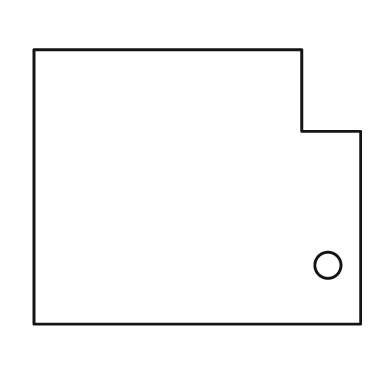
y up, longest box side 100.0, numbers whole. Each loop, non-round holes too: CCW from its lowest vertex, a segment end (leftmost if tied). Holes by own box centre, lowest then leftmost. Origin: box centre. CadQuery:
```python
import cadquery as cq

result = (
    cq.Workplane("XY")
    .moveTo(-50.0, -42.0)
    .lineTo(50.0, -42.0)
    .lineTo(50.0, 17.0)
    .lineTo(32.0, 17.0)
    .lineTo(32.0, 42.0)
    .lineTo(-50.0, 42.0)
    .close()
    .moveTo(40.0, -24.0)
    .circle(4.0)
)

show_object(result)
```